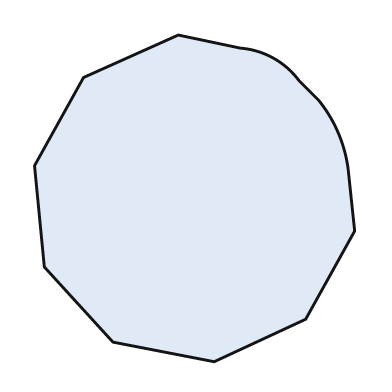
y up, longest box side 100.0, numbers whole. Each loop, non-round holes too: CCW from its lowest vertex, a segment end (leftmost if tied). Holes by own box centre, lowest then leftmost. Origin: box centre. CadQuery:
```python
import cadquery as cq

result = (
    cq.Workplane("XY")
    .moveTo(6.0, -50.0)
    .lineTo(34.0, -37.0)
    .lineTo(49.0, -10.0)
    .lineTo(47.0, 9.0)
    .threePointArc((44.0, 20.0), (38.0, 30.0))
    .lineTo(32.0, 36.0)
    .threePointArc((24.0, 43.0), (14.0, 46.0))
    .lineTo(-5.0, 50.0)
    .lineTo(-34.0, 37.0)
    .lineTo(-49.0, 10.0)
    .lineTo(-46.0, -21.0)
    .lineTo(-25.0, -44.0)
    .close()
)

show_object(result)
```